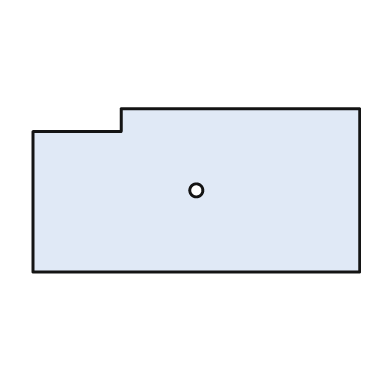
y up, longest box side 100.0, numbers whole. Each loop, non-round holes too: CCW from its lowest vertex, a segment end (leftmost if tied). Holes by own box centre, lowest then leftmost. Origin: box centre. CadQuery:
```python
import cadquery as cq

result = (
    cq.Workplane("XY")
    .moveTo(-50.0, -25.0)
    .lineTo(50.0, -25.0)
    .lineTo(50.0, 25.0)
    .lineTo(-23.0, 25.0)
    .lineTo(-23.0, 18.0)
    .lineTo(-50.0, 18.0)
    .close()
    .moveTo(0.0, 0.0)
    .circle(2.0)
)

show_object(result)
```